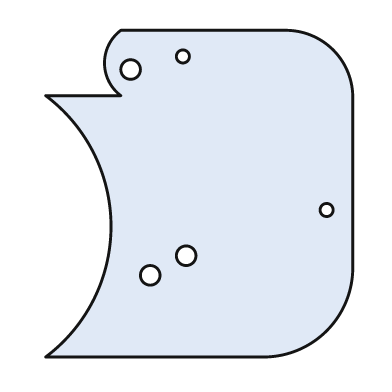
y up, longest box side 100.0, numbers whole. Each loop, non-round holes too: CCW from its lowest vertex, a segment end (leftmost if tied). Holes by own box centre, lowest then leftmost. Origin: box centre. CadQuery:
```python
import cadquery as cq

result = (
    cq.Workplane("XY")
    .moveTo(-47.0, -50.0)
    .lineTo(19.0, -50.0)
    .threePointArc((39.0, -42.0), (47.0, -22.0))
    .lineTo(47.0, 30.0)
    .threePointArc((41.0, 44.0), (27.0, 50.0))
    .lineTo(-24.0, 50.0)
    .threePointArc((-29.0, 40.0), (-24.0, 30.0))
    .lineTo(-47.0, 30.0)
    .threePointArc((-27.0, -10.0), (-47.0, -50.0))
    .close()
    .moveTo(-15.0, -25.0)
    .circle(3.0)
    .moveTo(-4.0, -19.0)
    .circle(3.0)
    .moveTo(39.0, -5.0)
    .circle(2.0)
    .moveTo(-21.0, 38.0)
    .circle(3.0)
    .moveTo(-5.0, 42.0)
    .circle(2.0)
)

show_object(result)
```